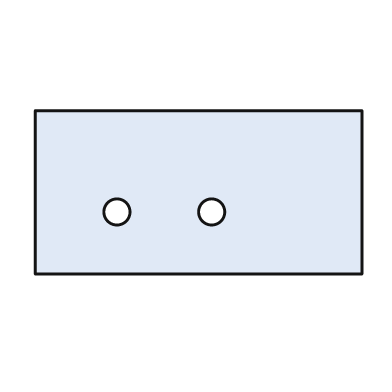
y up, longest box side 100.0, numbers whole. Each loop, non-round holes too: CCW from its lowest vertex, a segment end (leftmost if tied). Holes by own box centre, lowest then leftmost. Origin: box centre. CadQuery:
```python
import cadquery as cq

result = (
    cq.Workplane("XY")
    .moveTo(-50.0, -25.0)
    .lineTo(50.0, -25.0)
    .lineTo(50.0, 25.0)
    .lineTo(-50.0, 25.0)
    .close()
    .moveTo(-25.0, -6.0)
    .circle(4.0)
    .moveTo(4.0, -6.0)
    .circle(4.0)
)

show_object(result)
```